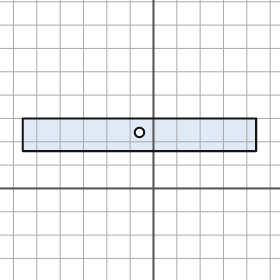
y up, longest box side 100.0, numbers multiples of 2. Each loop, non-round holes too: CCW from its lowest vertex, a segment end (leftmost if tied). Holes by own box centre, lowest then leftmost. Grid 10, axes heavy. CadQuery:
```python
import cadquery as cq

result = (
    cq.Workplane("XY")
    .moveTo(-56.0, 16.0)
    .lineTo(44.0, 16.0)
    .lineTo(44.0, 30.0)
    .lineTo(-56.0, 30.0)
    .close()
    .moveTo(-6.0, 24.0)
    .circle(2.0)
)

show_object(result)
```